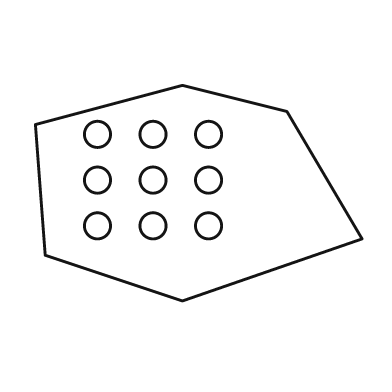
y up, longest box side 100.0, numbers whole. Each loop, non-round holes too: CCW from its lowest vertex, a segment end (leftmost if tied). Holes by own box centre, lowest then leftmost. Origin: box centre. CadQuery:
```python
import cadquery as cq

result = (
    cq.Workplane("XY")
    .moveTo(-5.0, -33.0)
    .lineTo(50.0, -14.0)
    .lineTo(27.0, 25.0)
    .lineTo(-5.0, 33.0)
    .lineTo(-50.0, 21.0)
    .lineTo(-47.0, -19.0)
    .close()
    .moveTo(-31.0, -10.0)
    .circle(4.0)
    .moveTo(-14.0, -10.0)
    .circle(4.0)
    .moveTo(3.0, -10.0)
    .circle(4.0)
    .moveTo(-31.0, 4.0)
    .circle(4.0)
    .moveTo(-14.0, 4.0)
    .circle(4.0)
    .moveTo(3.0, 4.0)
    .circle(4.0)
    .moveTo(-31.0, 18.0)
    .circle(4.0)
    .moveTo(-14.0, 18.0)
    .circle(4.0)
    .moveTo(3.0, 18.0)
    .circle(4.0)
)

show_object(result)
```